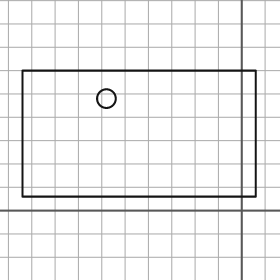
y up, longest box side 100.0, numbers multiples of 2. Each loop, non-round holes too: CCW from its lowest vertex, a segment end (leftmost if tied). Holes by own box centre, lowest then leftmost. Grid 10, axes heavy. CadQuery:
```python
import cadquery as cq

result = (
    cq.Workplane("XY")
    .moveTo(-94.0, 6.0)
    .lineTo(6.0, 6.0)
    .lineTo(6.0, 60.0)
    .lineTo(-94.0, 60.0)
    .close()
    .moveTo(-58.0, 48.0)
    .circle(4.0)
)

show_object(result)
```